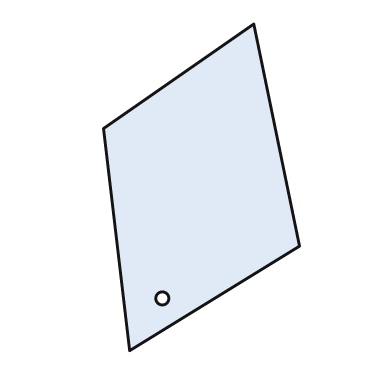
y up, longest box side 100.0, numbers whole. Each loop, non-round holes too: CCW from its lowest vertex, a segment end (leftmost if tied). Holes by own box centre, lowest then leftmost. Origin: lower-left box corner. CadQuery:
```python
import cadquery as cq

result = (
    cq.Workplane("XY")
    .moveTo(8.0, 0.0)
    .lineTo(60.0, 32.0)
    .lineTo(46.0, 100.0)
    .lineTo(0.0, 68.0)
    .close()
    .moveTo(18.0, 16.0)
    .circle(2.0)
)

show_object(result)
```